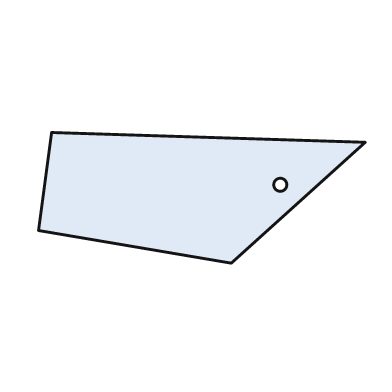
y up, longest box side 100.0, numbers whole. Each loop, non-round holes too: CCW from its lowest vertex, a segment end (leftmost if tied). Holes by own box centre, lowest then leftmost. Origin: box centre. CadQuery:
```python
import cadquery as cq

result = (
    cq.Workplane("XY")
    .moveTo(9.0, -20.0)
    .lineTo(50.0, 17.0)
    .lineTo(-46.0, 20.0)
    .lineTo(-50.0, -10.0)
    .close()
    .moveTo(24.0, 4.0)
    .circle(2.0)
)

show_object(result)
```